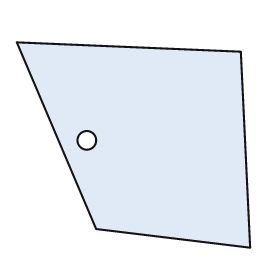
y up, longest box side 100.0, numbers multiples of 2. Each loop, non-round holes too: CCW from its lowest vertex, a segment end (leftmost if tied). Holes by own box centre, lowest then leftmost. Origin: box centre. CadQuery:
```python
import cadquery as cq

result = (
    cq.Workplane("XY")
    .moveTo(50.0, -44.0)
    .lineTo(46.0, 40.0)
    .lineTo(-50.0, 44.0)
    .lineTo(-16.0, -36.0)
    .close()
    .moveTo(-20.0, 2.0)
    .circle(4.0)
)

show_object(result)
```